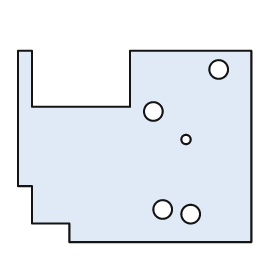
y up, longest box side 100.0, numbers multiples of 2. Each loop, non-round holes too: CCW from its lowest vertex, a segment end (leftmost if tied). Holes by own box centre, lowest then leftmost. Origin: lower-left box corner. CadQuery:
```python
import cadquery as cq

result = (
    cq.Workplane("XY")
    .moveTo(22.0, 0.0)
    .lineTo(100.0, 0.0)
    .lineTo(100.0, 82.0)
    .lineTo(48.0, 82.0)
    .lineTo(48.0, 58.0)
    .lineTo(6.0, 58.0)
    .lineTo(6.0, 82.0)
    .lineTo(0.0, 82.0)
    .lineTo(0.0, 24.0)
    .lineTo(6.0, 24.0)
    .lineTo(6.0, 8.0)
    .lineTo(22.0, 8.0)
    .close()
    .moveTo(74.0, 12.0)
    .circle(4.0)
    .moveTo(62.0, 14.0)
    .circle(4.0)
    .moveTo(72.0, 44.0)
    .circle(2.0)
    .moveTo(58.0, 56.0)
    .circle(4.0)
    .moveTo(86.0, 74.0)
    .circle(4.0)
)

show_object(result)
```